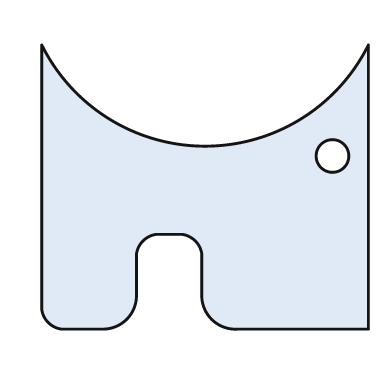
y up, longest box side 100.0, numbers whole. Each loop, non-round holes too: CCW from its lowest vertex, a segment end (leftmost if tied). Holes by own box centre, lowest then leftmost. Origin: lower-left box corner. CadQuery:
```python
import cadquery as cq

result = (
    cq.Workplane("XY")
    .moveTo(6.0, 0.0)
    .lineTo(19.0, 0.0)
    .threePointArc((26.0, 3.0), (29.0, 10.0))
    .lineTo(29.0, 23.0)
    .threePointArc((31.0, 27.0), (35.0, 29.0))
    .lineTo(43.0, 29.0)
    .threePointArc((47.0, 27.0), (49.0, 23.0))
    .lineTo(49.0, 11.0)
    .threePointArc((52.0, 3.0), (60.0, 0.0))
    .lineTo(100.0, 0.0)
    .lineTo(100.0, 87.0)
    .threePointArc((50.0, 56.0), (0.0, 87.0))
    .lineTo(0.0, 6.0)
    .threePointArc((2.0, 2.0), (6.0, 0.0))
    .close()
    .moveTo(89.0, 53.0)
    .circle(5.0)
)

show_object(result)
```